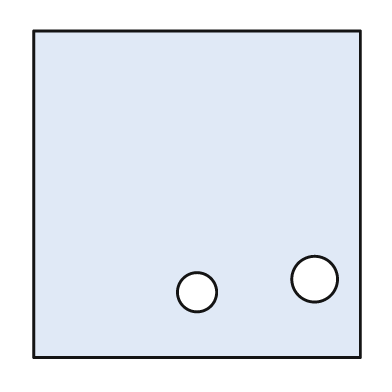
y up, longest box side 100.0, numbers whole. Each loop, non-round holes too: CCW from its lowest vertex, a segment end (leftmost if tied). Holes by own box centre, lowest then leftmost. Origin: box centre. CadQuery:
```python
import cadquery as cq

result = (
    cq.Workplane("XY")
    .moveTo(-50.0, -50.0)
    .lineTo(50.0, -50.0)
    .lineTo(50.0, 50.0)
    .lineTo(-50.0, 50.0)
    .close()
    .moveTo(0.0, -30.0)
    .circle(6.0)
    .moveTo(36.0, -26.0)
    .circle(7.0)
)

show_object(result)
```